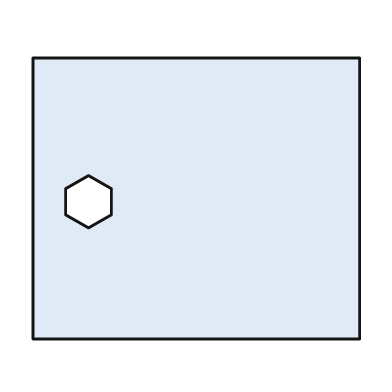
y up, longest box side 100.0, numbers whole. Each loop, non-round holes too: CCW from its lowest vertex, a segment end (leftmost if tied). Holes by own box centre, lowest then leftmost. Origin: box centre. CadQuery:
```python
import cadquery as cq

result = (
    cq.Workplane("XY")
    .moveTo(-50.0, -43.0)
    .lineTo(50.0, -43.0)
    .lineTo(50.0, 43.0)
    .lineTo(-50.0, 43.0)
    .close()
    .moveTo(-33.0, -9.0)
    .lineTo(-26.0, -5.0)
    .lineTo(-26.0, 3.0)
    .lineTo(-33.0, 7.0)
    .lineTo(-40.0, 3.0)
    .lineTo(-40.0, -5.0)
    .close()
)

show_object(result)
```